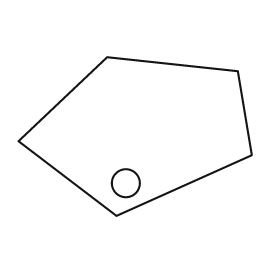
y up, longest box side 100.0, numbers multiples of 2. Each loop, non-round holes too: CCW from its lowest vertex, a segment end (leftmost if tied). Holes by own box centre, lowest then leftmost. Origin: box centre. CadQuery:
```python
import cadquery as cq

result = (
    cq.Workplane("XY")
    .moveTo(-8.0, -34.0)
    .lineTo(50.0, -8.0)
    .lineTo(44.0, 28.0)
    .lineTo(-12.0, 34.0)
    .lineTo(-50.0, -2.0)
    .close()
    .moveTo(-4.0, -20.0)
    .circle(6.0)
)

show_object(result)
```